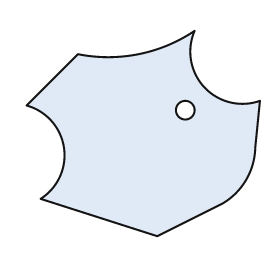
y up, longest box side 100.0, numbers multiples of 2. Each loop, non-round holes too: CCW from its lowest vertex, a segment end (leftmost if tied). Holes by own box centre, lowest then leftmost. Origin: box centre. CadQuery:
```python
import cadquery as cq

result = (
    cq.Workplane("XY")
    .moveTo(6.0, -44.0)
    .lineTo(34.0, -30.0)
    .threePointArc((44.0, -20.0), (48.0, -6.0))
    .lineTo(50.0, 14.0)
    .threePointArc((26.0, 20.0), (22.0, 44.0))
    .threePointArc((-2.0, 34.0), (-28.0, 34.0))
    .lineTo(-50.0, 12.0)
    .threePointArc((-34.0, -6.0), (-44.0, -28.0))
    .close()
    .moveTo(18.0, 10.0)
    .circle(4.0)
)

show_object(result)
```